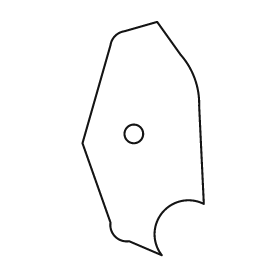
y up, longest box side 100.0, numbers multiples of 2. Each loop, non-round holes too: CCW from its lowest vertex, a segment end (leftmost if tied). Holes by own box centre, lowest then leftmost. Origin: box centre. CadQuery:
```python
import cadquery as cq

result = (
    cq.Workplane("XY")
    .moveTo(8.0, -50.0)
    .threePointArc((8.0, -32.0), (26.0, -28.0))
    .lineTo(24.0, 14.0)
    .threePointArc((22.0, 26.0), (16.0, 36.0))
    .lineTo(6.0, 50.0)
    .lineTo(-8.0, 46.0)
    .threePointArc((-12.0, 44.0), (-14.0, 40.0))
    .lineTo(-26.0, -2.0)
    .lineTo(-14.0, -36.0)
    .threePointArc((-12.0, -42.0), (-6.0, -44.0))
    .close()
    .moveTo(-4.0, 2.0)
    .circle(4.0)
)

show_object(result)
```